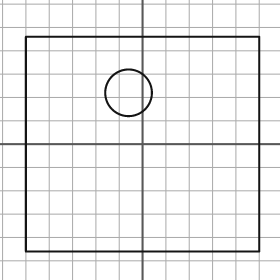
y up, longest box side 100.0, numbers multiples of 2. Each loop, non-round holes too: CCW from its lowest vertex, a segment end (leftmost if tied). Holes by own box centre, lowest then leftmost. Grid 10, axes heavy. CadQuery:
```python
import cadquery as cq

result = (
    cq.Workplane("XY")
    .moveTo(-50.0, -46.0)
    .lineTo(50.0, -46.0)
    .lineTo(50.0, 46.0)
    .lineTo(-50.0, 46.0)
    .close()
    .moveTo(-6.0, 22.0)
    .circle(10.0)
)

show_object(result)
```